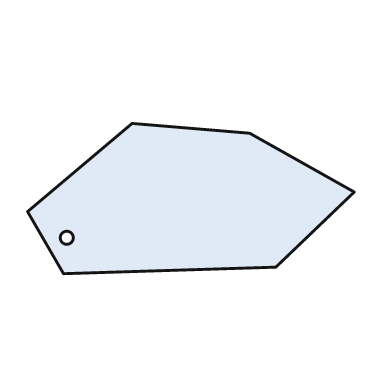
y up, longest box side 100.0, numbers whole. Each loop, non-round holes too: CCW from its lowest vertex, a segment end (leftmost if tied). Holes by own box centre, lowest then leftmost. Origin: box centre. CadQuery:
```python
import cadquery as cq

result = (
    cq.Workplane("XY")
    .moveTo(-39.0, -23.0)
    .lineTo(26.0, -21.0)
    .lineTo(50.0, 2.0)
    .lineTo(18.0, 20.0)
    .lineTo(-18.0, 23.0)
    .lineTo(-50.0, -4.0)
    .close()
    .moveTo(-38.0, -12.0)
    .circle(2.0)
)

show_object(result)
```